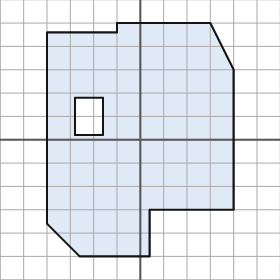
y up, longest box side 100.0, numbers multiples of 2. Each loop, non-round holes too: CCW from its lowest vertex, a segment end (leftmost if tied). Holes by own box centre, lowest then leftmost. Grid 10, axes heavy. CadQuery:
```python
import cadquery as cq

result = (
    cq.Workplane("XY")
    .moveTo(-26.0, -50.0)
    .lineTo(4.0, -50.0)
    .lineTo(4.0, -30.0)
    .lineTo(40.0, -30.0)
    .lineTo(40.0, 30.0)
    .lineTo(30.0, 50.0)
    .lineTo(-10.0, 50.0)
    .lineTo(-10.0, 46.0)
    .lineTo(-40.0, 46.0)
    .lineTo(-40.0, -36.0)
    .close()
    .moveTo(-28.0, 2.0)
    .lineTo(-16.0, 2.0)
    .lineTo(-16.0, 18.0)
    .lineTo(-28.0, 18.0)
    .close()
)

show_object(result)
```